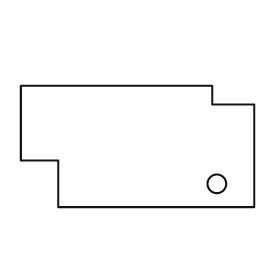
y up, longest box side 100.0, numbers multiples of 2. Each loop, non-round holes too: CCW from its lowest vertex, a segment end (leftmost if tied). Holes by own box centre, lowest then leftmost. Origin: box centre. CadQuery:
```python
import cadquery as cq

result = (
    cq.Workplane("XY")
    .moveTo(-34.0, -26.0)
    .lineTo(50.0, -26.0)
    .lineTo(50.0, 18.0)
    .lineTo(32.0, 18.0)
    .lineTo(32.0, 26.0)
    .lineTo(-50.0, 26.0)
    .lineTo(-50.0, -6.0)
    .lineTo(-34.0, -6.0)
    .close()
    .moveTo(34.0, -16.0)
    .circle(4.0)
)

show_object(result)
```